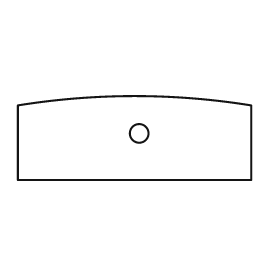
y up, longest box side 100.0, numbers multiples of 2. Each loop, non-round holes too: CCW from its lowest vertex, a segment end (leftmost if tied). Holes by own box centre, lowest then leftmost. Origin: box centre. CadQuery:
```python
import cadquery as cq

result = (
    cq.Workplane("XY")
    .moveTo(-50.0, -18.0)
    .lineTo(50.0, -18.0)
    .lineTo(50.0, 14.0)
    .threePointArc((0.0, 18.0), (-50.0, 14.0))
    .close()
    .moveTo(2.0, 2.0)
    .circle(4.0)
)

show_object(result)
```